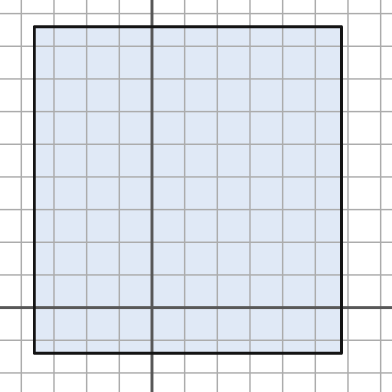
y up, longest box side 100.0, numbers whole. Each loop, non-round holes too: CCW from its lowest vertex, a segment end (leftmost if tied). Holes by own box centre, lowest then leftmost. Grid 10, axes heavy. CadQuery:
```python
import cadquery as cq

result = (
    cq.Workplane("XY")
    .moveTo(-36.0, -14.0)
    .lineTo(58.0, -14.0)
    .lineTo(58.0, 86.0)
    .lineTo(-36.0, 86.0)
    .close()
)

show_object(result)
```